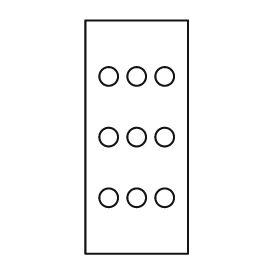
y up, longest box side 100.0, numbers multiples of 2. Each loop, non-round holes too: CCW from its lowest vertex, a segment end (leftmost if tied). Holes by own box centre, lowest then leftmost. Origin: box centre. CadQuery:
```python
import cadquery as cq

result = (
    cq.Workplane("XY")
    .moveTo(-22.0, -50.0)
    .lineTo(22.0, -50.0)
    .lineTo(22.0, 50.0)
    .lineTo(-22.0, 50.0)
    .close()
    .moveTo(-12.0, -26.0)
    .circle(4.0)
    .moveTo(0.0, -26.0)
    .circle(4.0)
    .moveTo(12.0, -26.0)
    .circle(4.0)
    .moveTo(-12.0, 0.0)
    .circle(4.0)
    .moveTo(0.0, 0.0)
    .circle(4.0)
    .moveTo(12.0, 0.0)
    .circle(4.0)
    .moveTo(-12.0, 26.0)
    .circle(4.0)
    .moveTo(0.0, 26.0)
    .circle(4.0)
    .moveTo(12.0, 26.0)
    .circle(4.0)
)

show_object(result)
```